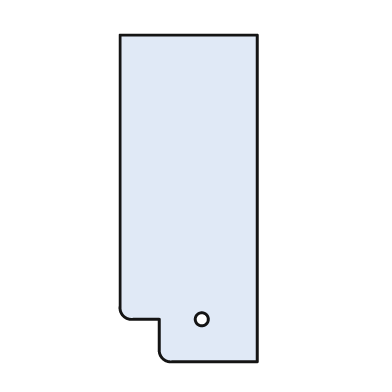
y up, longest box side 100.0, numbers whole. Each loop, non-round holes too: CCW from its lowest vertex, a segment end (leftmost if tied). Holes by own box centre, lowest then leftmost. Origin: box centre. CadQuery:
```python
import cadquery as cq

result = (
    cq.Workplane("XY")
    .moveTo(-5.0, -50.0)
    .lineTo(21.0, -50.0)
    .lineTo(21.0, 50.0)
    .lineTo(-21.0, 50.0)
    .lineTo(-21.0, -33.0)
    .threePointArc((-20.0, -36.0), (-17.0, -37.0))
    .lineTo(-9.0, -37.0)
    .lineTo(-9.0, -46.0)
    .threePointArc((-8.0, -49.0), (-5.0, -50.0))
    .close()
    .moveTo(4.0, -37.0)
    .circle(2.0)
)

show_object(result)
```